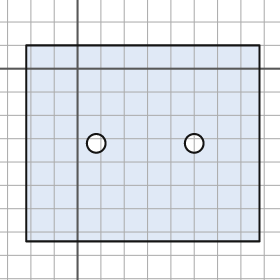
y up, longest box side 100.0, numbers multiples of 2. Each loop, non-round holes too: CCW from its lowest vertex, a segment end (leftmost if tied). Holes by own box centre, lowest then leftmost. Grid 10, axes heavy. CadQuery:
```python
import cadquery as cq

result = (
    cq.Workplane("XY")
    .moveTo(-22.0, -74.0)
    .lineTo(78.0, -74.0)
    .lineTo(78.0, 10.0)
    .lineTo(-22.0, 10.0)
    .close()
    .moveTo(8.0, -32.0)
    .circle(4.0)
    .moveTo(50.0, -32.0)
    .circle(4.0)
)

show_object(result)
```